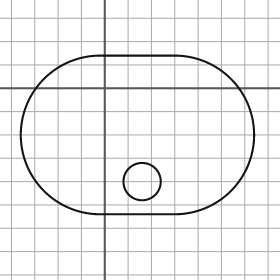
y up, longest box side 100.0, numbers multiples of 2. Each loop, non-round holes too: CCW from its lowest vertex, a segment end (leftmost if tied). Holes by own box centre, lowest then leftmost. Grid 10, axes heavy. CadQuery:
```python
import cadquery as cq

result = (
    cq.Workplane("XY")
    .moveTo(-2.0, -54.0)
    .lineTo(30.0, -54.0)
    .threePointArc((64.0, -20.0), (30.0, 14.0))
    .lineTo(-2.0, 14.0)
    .threePointArc((-36.0, -20.0), (-2.0, -54.0))
    .close()
    .moveTo(16.0, -40.0)
    .circle(8.0)
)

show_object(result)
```